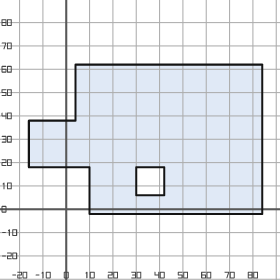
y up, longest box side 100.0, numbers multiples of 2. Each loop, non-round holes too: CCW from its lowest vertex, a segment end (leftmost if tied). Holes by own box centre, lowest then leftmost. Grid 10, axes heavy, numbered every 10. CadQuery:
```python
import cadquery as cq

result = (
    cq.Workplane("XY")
    .moveTo(10.0, -2.0)
    .lineTo(84.0, -2.0)
    .lineTo(84.0, 62.0)
    .lineTo(4.0, 62.0)
    .lineTo(4.0, 38.0)
    .lineTo(-16.0, 38.0)
    .lineTo(-16.0, 18.0)
    .lineTo(10.0, 18.0)
    .close()
    .moveTo(30.0, 6.0)
    .lineTo(42.0, 6.0)
    .lineTo(42.0, 18.0)
    .lineTo(30.0, 18.0)
    .close()
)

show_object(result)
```